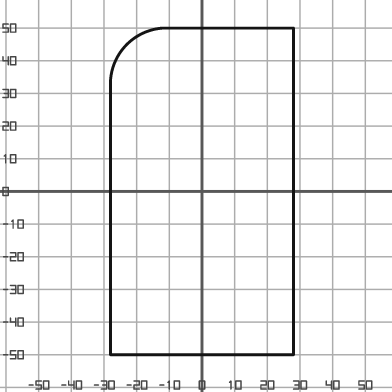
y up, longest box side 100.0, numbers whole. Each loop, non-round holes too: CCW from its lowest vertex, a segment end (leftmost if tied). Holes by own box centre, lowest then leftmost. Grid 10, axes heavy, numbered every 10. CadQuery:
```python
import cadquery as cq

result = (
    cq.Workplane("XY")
    .moveTo(-28.0, -50.0)
    .lineTo(28.0, -50.0)
    .lineTo(28.0, 50.0)
    .lineTo(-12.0, 50.0)
    .threePointArc((-23.0, 45.0), (-28.0, 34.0))
    .close()
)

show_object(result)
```